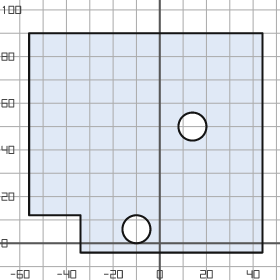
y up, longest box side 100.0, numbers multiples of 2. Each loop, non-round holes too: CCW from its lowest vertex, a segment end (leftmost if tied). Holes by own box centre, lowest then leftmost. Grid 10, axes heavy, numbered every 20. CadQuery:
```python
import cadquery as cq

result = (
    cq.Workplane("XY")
    .moveTo(-34.0, -4.0)
    .lineTo(44.0, -4.0)
    .lineTo(44.0, 90.0)
    .lineTo(-56.0, 90.0)
    .lineTo(-56.0, 12.0)
    .lineTo(-34.0, 12.0)
    .close()
    .moveTo(-10.0, 6.0)
    .circle(6.0)
    .moveTo(14.0, 50.0)
    .circle(6.0)
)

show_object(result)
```